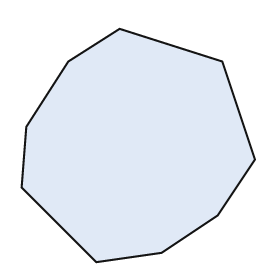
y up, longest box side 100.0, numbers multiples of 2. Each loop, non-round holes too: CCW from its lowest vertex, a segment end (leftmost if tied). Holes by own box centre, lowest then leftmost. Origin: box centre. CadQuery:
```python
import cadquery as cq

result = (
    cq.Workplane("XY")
    .moveTo(-18.0, -50.0)
    .lineTo(10.0, -46.0)
    .lineTo(34.0, -30.0)
    .lineTo(50.0, -6.0)
    .lineTo(36.0, 36.0)
    .lineTo(-8.0, 50.0)
    .lineTo(-30.0, 36.0)
    .lineTo(-48.0, 8.0)
    .lineTo(-50.0, -18.0)
    .close()
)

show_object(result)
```